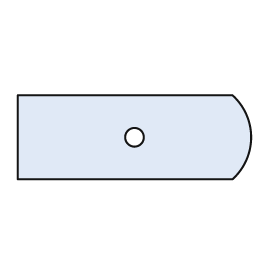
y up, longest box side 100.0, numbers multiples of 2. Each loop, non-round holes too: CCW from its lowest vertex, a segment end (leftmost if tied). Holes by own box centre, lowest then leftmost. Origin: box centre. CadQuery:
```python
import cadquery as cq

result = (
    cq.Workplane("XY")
    .moveTo(-50.0, -18.0)
    .lineTo(42.0, -18.0)
    .threePointArc((50.0, 0.0), (42.0, 18.0))
    .lineTo(-50.0, 18.0)
    .close()
    .moveTo(0.0, 0.0)
    .circle(4.0)
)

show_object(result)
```